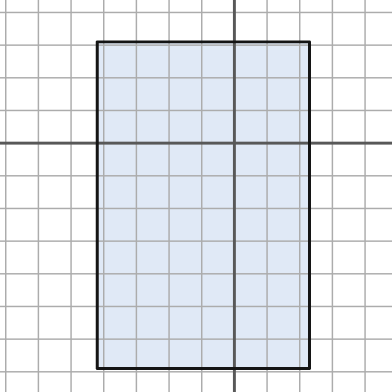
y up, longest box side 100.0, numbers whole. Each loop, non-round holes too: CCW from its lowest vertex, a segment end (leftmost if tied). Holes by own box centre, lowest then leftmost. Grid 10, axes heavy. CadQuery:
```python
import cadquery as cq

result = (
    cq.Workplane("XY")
    .moveTo(-42.0, -69.0)
    .lineTo(23.0, -69.0)
    .lineTo(23.0, 31.0)
    .lineTo(-42.0, 31.0)
    .close()
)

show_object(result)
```